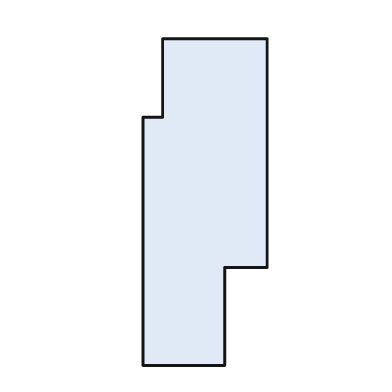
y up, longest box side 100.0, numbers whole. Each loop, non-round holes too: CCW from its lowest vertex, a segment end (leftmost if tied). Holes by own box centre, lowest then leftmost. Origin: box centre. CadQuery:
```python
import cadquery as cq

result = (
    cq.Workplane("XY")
    .moveTo(-19.0, -50.0)
    .lineTo(6.0, -50.0)
    .lineTo(6.0, -20.0)
    .lineTo(19.0, -20.0)
    .lineTo(19.0, 50.0)
    .lineTo(-13.0, 50.0)
    .lineTo(-13.0, 26.0)
    .lineTo(-19.0, 26.0)
    .close()
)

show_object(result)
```